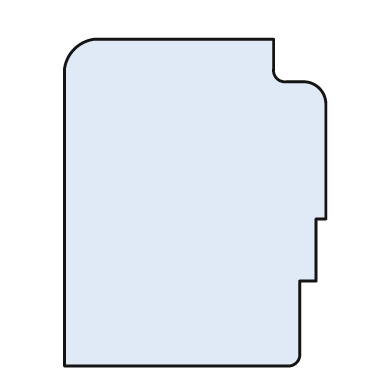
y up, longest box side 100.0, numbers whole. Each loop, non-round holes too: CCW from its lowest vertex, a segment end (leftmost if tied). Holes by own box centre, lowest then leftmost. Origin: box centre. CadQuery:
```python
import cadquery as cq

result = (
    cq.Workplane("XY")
    .moveTo(-40.0, -50.0)
    .lineTo(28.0, -50.0)
    .threePointArc((31.0, -49.0), (32.0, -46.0))
    .lineTo(32.0, -24.0)
    .lineTo(37.0, -24.0)
    .lineTo(37.0, -5.0)
    .lineTo(40.0, -5.0)
    .lineTo(40.0, 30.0)
    .threePointArc((38.0, 35.0), (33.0, 37.0))
    .lineTo(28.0, 37.0)
    .threePointArc((25.0, 38.0), (24.0, 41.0))
    .lineTo(24.0, 50.0)
    .lineTo(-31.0, 50.0)
    .threePointArc((-37.0, 47.0), (-40.0, 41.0))
    .close()
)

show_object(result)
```